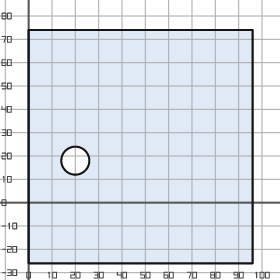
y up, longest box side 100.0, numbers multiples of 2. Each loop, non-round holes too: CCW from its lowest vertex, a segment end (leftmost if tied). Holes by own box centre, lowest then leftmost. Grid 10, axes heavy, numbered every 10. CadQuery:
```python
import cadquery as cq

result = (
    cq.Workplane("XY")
    .moveTo(0.0, -26.0)
    .lineTo(96.0, -26.0)
    .lineTo(96.0, 74.0)
    .lineTo(0.0, 74.0)
    .close()
    .moveTo(20.0, 18.0)
    .circle(6.0)
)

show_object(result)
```